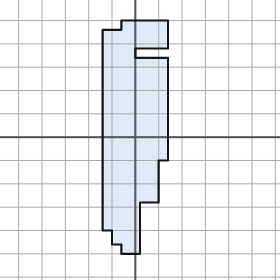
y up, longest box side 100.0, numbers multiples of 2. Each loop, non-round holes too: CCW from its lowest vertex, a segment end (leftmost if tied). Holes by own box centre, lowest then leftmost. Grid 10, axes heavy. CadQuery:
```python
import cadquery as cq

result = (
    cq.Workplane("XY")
    .moveTo(-6.0, -50.0)
    .lineTo(2.0, -50.0)
    .lineTo(2.0, -28.0)
    .lineTo(10.0, -28.0)
    .lineTo(10.0, -10.0)
    .lineTo(14.0, -10.0)
    .lineTo(14.0, 34.0)
    .lineTo(0.0, 34.0)
    .lineTo(0.0, 38.0)
    .lineTo(14.0, 38.0)
    .lineTo(14.0, 50.0)
    .lineTo(-6.0, 50.0)
    .lineTo(-6.0, 46.0)
    .lineTo(-14.0, 46.0)
    .lineTo(-14.0, -40.0)
    .lineTo(-10.0, -40.0)
    .lineTo(-10.0, -46.0)
    .lineTo(-6.0, -46.0)
    .close()
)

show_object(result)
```